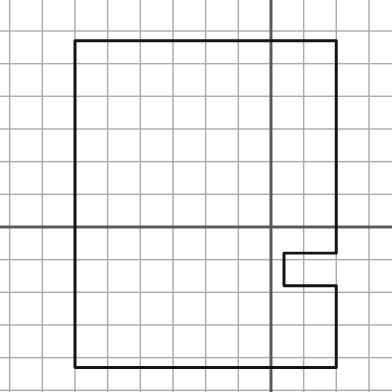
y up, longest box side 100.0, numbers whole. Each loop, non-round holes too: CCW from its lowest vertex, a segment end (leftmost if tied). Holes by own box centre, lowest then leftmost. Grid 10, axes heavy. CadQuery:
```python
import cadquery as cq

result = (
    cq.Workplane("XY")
    .moveTo(-60.0, -43.0)
    .lineTo(20.0, -43.0)
    .lineTo(20.0, -18.0)
    .lineTo(4.0, -18.0)
    .lineTo(4.0, -8.0)
    .lineTo(20.0, -8.0)
    .lineTo(20.0, 57.0)
    .lineTo(-60.0, 57.0)
    .close()
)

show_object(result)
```